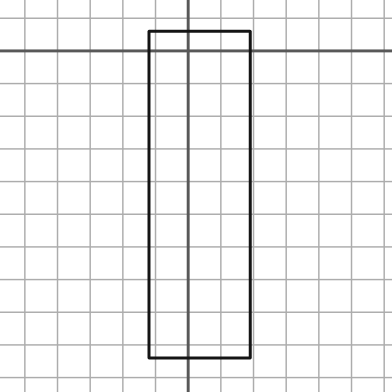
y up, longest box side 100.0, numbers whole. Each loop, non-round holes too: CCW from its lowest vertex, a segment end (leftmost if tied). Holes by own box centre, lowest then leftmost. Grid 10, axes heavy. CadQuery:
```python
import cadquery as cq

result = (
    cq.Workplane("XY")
    .moveTo(-12.0, -94.0)
    .lineTo(19.0, -94.0)
    .lineTo(19.0, 6.0)
    .lineTo(-12.0, 6.0)
    .close()
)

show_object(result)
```